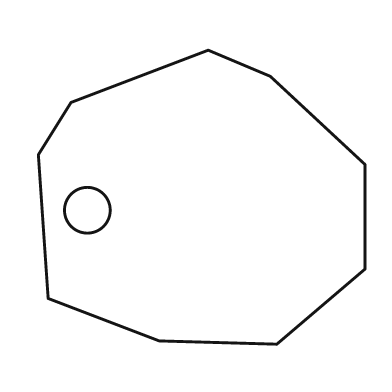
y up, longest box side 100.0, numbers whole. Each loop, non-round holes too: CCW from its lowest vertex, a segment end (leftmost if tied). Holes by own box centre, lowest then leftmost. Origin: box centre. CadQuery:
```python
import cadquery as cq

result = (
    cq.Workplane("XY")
    .moveTo(23.0, -45.0)
    .lineTo(50.0, -22.0)
    .lineTo(50.0, 10.0)
    .lineTo(21.0, 37.0)
    .lineTo(2.0, 45.0)
    .lineTo(-40.0, 29.0)
    .lineTo(-50.0, 13.0)
    .lineTo(-47.0, -31.0)
    .lineTo(-13.0, -44.0)
    .close()
    .moveTo(-35.0, -4.0)
    .circle(7.0)
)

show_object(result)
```